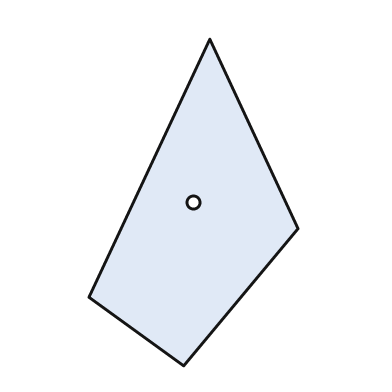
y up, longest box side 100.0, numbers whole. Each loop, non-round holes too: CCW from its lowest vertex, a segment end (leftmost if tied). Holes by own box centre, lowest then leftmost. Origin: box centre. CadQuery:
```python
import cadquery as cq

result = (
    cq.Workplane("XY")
    .moveTo(-3.0, -50.0)
    .lineTo(32.0, -8.0)
    .lineTo(5.0, 50.0)
    .lineTo(-32.0, -29.0)
    .close()
    .moveTo(0.0, 0.0)
    .circle(2.0)
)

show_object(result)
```